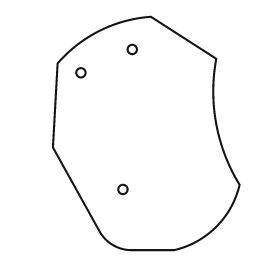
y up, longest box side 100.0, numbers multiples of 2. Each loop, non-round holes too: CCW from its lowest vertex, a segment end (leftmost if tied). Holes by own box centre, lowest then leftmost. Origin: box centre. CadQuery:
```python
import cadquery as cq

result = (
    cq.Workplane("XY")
    .moveTo(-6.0, -50.0)
    .lineTo(12.0, -50.0)
    .threePointArc((30.0, -40.0), (40.0, -22.0))
    .threePointArc((30.0, 4.0), (30.0, 32.0))
    .lineTo(2.0, 50.0)
    .threePointArc((-20.0, 44.0), (-38.0, 30.0))
    .lineTo(-40.0, -6.0)
    .lineTo(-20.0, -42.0)
    .threePointArc((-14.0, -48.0), (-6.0, -50.0))
    .close()
    .moveTo(-10.0, -24.0)
    .circle(2.0)
    .moveTo(-28.0, 26.0)
    .circle(2.0)
    .moveTo(-6.0, 36.0)
    .circle(2.0)
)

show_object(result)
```